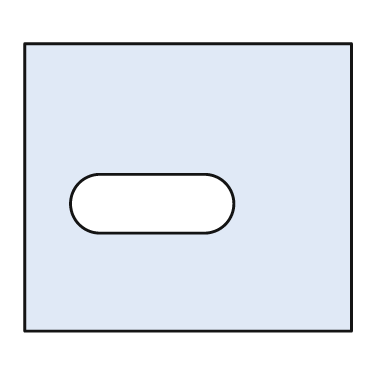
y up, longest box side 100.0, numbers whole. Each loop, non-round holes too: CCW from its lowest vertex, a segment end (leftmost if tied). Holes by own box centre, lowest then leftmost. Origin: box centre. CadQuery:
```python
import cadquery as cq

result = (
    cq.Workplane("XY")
    .moveTo(-50.0, -44.0)
    .lineTo(50.0, -44.0)
    .lineTo(50.0, 44.0)
    .lineTo(-50.0, 44.0)
    .close()
    .moveTo(-27.0, -14.0)
    .lineTo(5.0, -14.0)
    .threePointArc((14.0, -5.0), (5.0, 4.0))
    .lineTo(-27.0, 4.0)
    .threePointArc((-36.0, -5.0), (-27.0, -14.0))
    .close()
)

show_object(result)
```